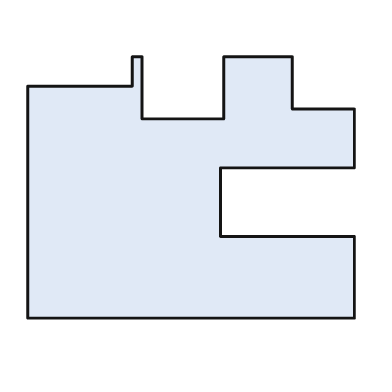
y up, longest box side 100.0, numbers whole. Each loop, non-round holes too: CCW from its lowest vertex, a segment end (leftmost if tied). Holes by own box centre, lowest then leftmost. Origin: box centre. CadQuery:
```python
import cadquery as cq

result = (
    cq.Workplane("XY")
    .moveTo(-50.0, -40.0)
    .lineTo(50.0, -40.0)
    .lineTo(50.0, -15.0)
    .lineTo(9.0, -15.0)
    .lineTo(9.0, 6.0)
    .lineTo(50.0, 6.0)
    .lineTo(50.0, 24.0)
    .lineTo(31.0, 24.0)
    .lineTo(31.0, 40.0)
    .lineTo(10.0, 40.0)
    .lineTo(10.0, 21.0)
    .lineTo(-15.0, 21.0)
    .lineTo(-15.0, 40.0)
    .lineTo(-18.0, 40.0)
    .lineTo(-18.0, 31.0)
    .lineTo(-50.0, 31.0)
    .close()
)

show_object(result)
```